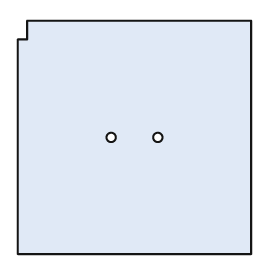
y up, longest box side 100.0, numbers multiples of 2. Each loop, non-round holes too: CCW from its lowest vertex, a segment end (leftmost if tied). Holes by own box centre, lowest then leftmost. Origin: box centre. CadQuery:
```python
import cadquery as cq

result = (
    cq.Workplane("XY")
    .moveTo(-50.0, -50.0)
    .lineTo(50.0, -50.0)
    .lineTo(50.0, 50.0)
    .lineTo(-46.0, 50.0)
    .lineTo(-46.0, 42.0)
    .lineTo(-50.0, 42.0)
    .close()
    .moveTo(-10.0, 0.0)
    .circle(2.0)
    .moveTo(10.0, 0.0)
    .circle(2.0)
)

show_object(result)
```